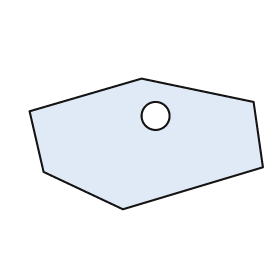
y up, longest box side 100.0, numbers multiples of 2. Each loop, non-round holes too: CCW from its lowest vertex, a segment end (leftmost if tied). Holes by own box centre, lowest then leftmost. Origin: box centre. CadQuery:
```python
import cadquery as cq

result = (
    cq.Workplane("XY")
    .moveTo(-10.0, -28.0)
    .lineTo(50.0, -10.0)
    .lineTo(46.0, 18.0)
    .lineTo(-2.0, 28.0)
    .lineTo(-50.0, 14.0)
    .lineTo(-44.0, -12.0)
    .close()
    .moveTo(4.0, 12.0)
    .circle(6.0)
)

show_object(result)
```